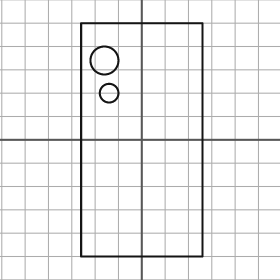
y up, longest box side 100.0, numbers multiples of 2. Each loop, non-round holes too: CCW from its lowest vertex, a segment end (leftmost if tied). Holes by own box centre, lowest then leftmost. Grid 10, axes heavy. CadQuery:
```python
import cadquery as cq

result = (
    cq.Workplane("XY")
    .moveTo(-26.0, -50.0)
    .lineTo(26.0, -50.0)
    .lineTo(26.0, 50.0)
    .lineTo(-26.0, 50.0)
    .close()
    .moveTo(-14.0, 20.0)
    .circle(4.0)
    .moveTo(-16.0, 34.0)
    .circle(6.0)
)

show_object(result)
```